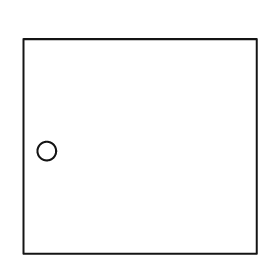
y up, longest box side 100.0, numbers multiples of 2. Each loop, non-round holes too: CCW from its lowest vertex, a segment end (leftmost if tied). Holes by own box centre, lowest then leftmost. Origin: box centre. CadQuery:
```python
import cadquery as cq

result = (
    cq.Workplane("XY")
    .moveTo(-50.0, -46.0)
    .lineTo(50.0, -46.0)
    .lineTo(50.0, 46.0)
    .lineTo(-50.0, 46.0)
    .close()
    .moveTo(-40.0, -2.0)
    .circle(4.0)
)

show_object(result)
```